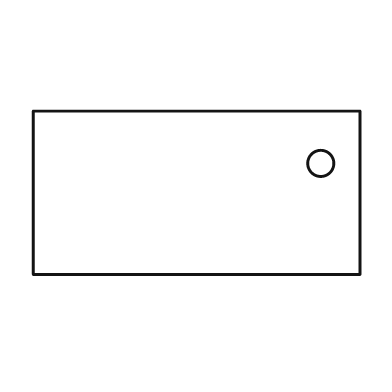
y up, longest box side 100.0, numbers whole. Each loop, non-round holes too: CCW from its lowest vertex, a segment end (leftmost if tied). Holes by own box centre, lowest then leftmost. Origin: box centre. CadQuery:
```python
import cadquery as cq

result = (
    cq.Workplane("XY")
    .moveTo(-50.0, -25.0)
    .lineTo(50.0, -25.0)
    .lineTo(50.0, 25.0)
    .lineTo(-50.0, 25.0)
    .close()
    .moveTo(38.0, 9.0)
    .circle(4.0)
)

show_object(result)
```